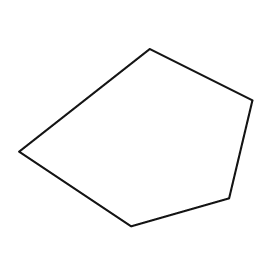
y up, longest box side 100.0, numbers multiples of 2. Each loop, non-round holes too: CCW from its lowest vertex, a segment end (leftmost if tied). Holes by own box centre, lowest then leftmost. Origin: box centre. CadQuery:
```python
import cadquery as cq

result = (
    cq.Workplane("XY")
    .moveTo(-2.0, -38.0)
    .lineTo(40.0, -26.0)
    .lineTo(50.0, 16.0)
    .lineTo(6.0, 38.0)
    .lineTo(-50.0, -6.0)
    .close()
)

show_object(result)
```